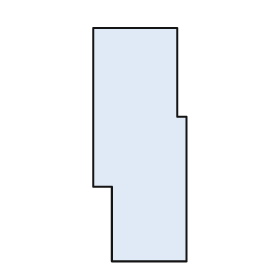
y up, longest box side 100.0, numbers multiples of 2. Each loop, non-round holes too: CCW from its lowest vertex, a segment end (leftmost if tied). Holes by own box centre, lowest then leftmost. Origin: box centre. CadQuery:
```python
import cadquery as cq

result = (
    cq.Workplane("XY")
    .moveTo(-12.0, -50.0)
    .lineTo(20.0, -50.0)
    .lineTo(20.0, 12.0)
    .lineTo(16.0, 12.0)
    .lineTo(16.0, 50.0)
    .lineTo(-20.0, 50.0)
    .lineTo(-20.0, -18.0)
    .lineTo(-12.0, -18.0)
    .close()
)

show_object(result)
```